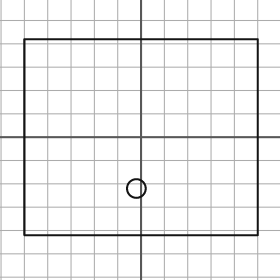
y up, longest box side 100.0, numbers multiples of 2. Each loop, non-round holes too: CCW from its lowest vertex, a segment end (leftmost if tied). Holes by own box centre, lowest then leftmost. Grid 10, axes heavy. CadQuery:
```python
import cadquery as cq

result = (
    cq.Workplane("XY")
    .moveTo(-50.0, -42.0)
    .lineTo(50.0, -42.0)
    .lineTo(50.0, 42.0)
    .lineTo(-50.0, 42.0)
    .close()
    .moveTo(-2.0, -22.0)
    .circle(4.0)
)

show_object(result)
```